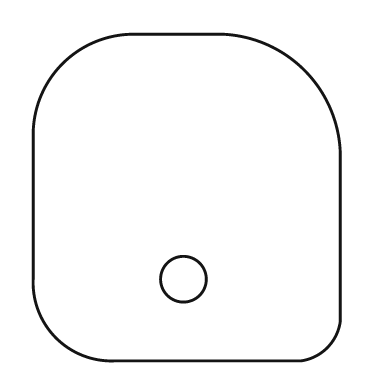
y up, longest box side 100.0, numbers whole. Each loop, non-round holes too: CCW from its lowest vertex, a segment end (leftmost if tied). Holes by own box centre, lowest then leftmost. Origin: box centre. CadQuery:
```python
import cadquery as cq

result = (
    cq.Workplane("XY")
    .moveTo(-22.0, -50.0)
    .lineTo(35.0, -50.0)
    .threePointArc((43.0, -46.0), (47.0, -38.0))
    .lineTo(47.0, 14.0)
    .threePointArc((36.0, 39.0), (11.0, 50.0))
    .lineTo(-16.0, 50.0)
    .threePointArc((-38.0, 41.0), (-47.0, 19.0))
    .lineTo(-47.0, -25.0)
    .threePointArc((-40.0, -43.0), (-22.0, -50.0))
    .close()
    .moveTo(-1.0, -25.0)
    .circle(7.0)
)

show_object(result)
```